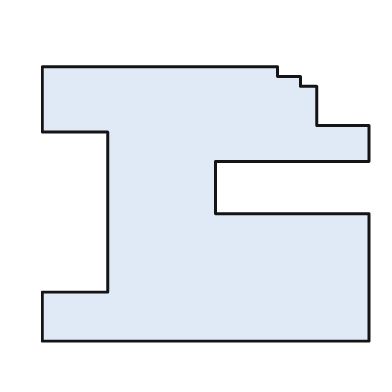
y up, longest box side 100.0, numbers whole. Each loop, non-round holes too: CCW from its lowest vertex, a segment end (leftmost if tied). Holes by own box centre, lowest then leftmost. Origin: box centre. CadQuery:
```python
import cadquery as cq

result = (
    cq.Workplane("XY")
    .moveTo(-50.0, -42.0)
    .lineTo(50.0, -42.0)
    .lineTo(50.0, -3.0)
    .lineTo(3.0, -3.0)
    .lineTo(3.0, 13.0)
    .lineTo(50.0, 13.0)
    .lineTo(50.0, 24.0)
    .lineTo(34.0, 24.0)
    .lineTo(34.0, 36.0)
    .lineTo(29.0, 36.0)
    .lineTo(29.0, 39.0)
    .lineTo(22.0, 39.0)
    .lineTo(22.0, 42.0)
    .lineTo(-50.0, 42.0)
    .lineTo(-50.0, 22.0)
    .lineTo(-30.0, 22.0)
    .lineTo(-30.0, -27.0)
    .lineTo(-50.0, -27.0)
    .close()
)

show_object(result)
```